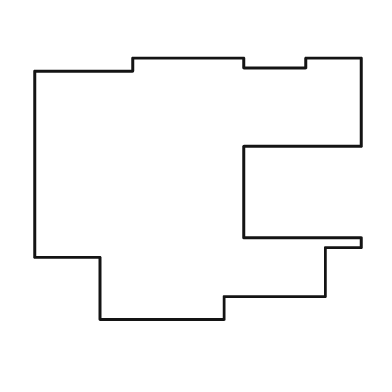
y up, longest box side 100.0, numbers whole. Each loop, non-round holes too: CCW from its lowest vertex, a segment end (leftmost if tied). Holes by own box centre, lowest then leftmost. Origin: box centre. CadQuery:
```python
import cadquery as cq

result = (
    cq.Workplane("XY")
    .moveTo(-30.0, -40.0)
    .lineTo(8.0, -40.0)
    .lineTo(8.0, -33.0)
    .lineTo(39.0, -33.0)
    .lineTo(39.0, -18.0)
    .lineTo(50.0, -18.0)
    .lineTo(50.0, -15.0)
    .lineTo(14.0, -15.0)
    .lineTo(14.0, 13.0)
    .lineTo(50.0, 13.0)
    .lineTo(50.0, 40.0)
    .lineTo(33.0, 40.0)
    .lineTo(33.0, 37.0)
    .lineTo(14.0, 37.0)
    .lineTo(14.0, 40.0)
    .lineTo(-20.0, 40.0)
    .lineTo(-20.0, 36.0)
    .lineTo(-50.0, 36.0)
    .lineTo(-50.0, -21.0)
    .lineTo(-30.0, -21.0)
    .close()
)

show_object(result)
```